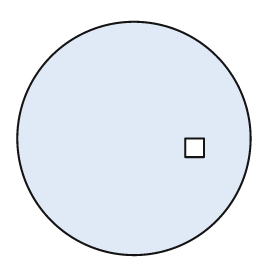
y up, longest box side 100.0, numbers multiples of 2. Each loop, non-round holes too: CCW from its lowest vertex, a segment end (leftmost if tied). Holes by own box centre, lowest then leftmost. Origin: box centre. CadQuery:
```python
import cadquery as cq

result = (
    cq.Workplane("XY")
    .moveTo(0.0, 0.0)
    .circle(50.0)
    .moveTo(22.0, -8.0)
    .lineTo(30.0, -8.0)
    .lineTo(30.0, 0.0)
    .lineTo(22.0, 0.0)
    .close()
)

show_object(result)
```